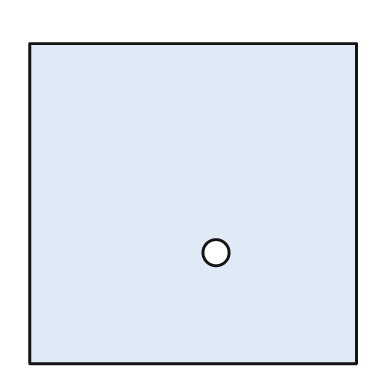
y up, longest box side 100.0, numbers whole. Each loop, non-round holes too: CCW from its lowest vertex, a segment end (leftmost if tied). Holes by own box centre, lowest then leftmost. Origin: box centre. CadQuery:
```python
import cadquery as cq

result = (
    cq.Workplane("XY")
    .moveTo(-50.0, -49.0)
    .lineTo(50.0, -49.0)
    .lineTo(50.0, 49.0)
    .lineTo(-50.0, 49.0)
    .close()
    .moveTo(7.0, -15.0)
    .circle(4.0)
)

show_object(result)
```